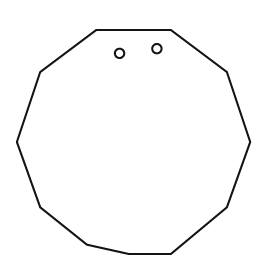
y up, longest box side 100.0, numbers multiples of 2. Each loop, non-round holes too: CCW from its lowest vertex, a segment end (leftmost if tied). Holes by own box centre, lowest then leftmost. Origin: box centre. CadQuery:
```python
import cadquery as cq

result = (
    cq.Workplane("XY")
    .moveTo(-2.0, -48.0)
    .lineTo(16.0, -48.0)
    .lineTo(40.0, -28.0)
    .lineTo(50.0, 0.0)
    .lineTo(40.0, 30.0)
    .lineTo(16.0, 48.0)
    .lineTo(-16.0, 48.0)
    .lineTo(-40.0, 30.0)
    .lineTo(-50.0, 0.0)
    .lineTo(-40.0, -28.0)
    .lineTo(-20.0, -44.0)
    .close()
    .moveTo(-6.0, 38.0)
    .circle(2.0)
    .moveTo(10.0, 40.0)
    .circle(2.0)
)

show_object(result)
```